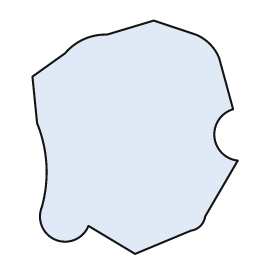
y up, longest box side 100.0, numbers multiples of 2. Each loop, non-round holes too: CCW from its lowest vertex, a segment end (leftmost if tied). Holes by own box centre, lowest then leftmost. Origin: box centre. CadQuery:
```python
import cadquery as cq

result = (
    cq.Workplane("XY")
    .moveTo(0.0, -50.0)
    .lineTo(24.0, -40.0)
    .threePointArc((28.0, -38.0), (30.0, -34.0))
    .lineTo(44.0, -10.0)
    .threePointArc((34.0, 0.0), (42.0, 12.0))
    .lineTo(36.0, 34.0)
    .threePointArc((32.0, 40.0), (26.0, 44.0))
    .lineTo(8.0, 50.0)
    .lineTo(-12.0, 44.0)
    .threePointArc((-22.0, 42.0), (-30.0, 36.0))
    .lineTo(-44.0, 26.0)
    .lineTo(-42.0, 6.0)
    .threePointArc((-38.0, -12.0), (-40.0, -30.0))
    .threePointArc((-34.0, -44.0), (-20.0, -38.0))
    .close()
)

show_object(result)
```